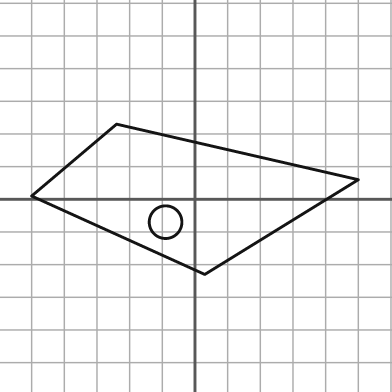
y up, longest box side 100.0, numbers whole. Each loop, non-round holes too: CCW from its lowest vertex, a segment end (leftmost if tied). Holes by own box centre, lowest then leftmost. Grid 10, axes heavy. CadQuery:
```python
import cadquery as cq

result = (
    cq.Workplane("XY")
    .moveTo(3.0, -23.0)
    .lineTo(50.0, 6.0)
    .lineTo(-24.0, 23.0)
    .lineTo(-50.0, 1.0)
    .close()
    .moveTo(-9.0, -7.0)
    .circle(5.0)
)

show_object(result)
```